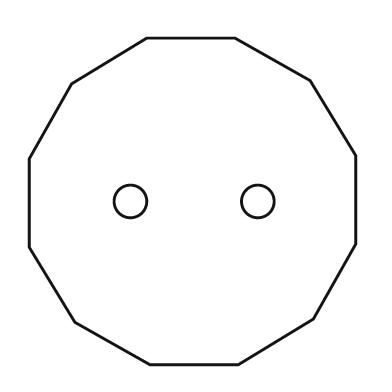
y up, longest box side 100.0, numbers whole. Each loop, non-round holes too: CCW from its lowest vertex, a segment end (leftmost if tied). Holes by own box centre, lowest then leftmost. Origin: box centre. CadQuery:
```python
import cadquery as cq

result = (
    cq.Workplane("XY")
    .moveTo(-13.0, -50.0)
    .lineTo(14.0, -50.0)
    .lineTo(37.0, -36.0)
    .lineTo(50.0, -13.0)
    .lineTo(50.0, 14.0)
    .lineTo(36.0, 37.0)
    .lineTo(13.0, 50.0)
    .lineTo(-14.0, 50.0)
    .lineTo(-37.0, 36.0)
    .lineTo(-50.0, 13.0)
    .lineTo(-50.0, -14.0)
    .lineTo(-36.0, -37.0)
    .close()
    .moveTo(-19.0, 0.0)
    .circle(5.0)
    .moveTo(20.0, 0.0)
    .circle(5.0)
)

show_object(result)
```